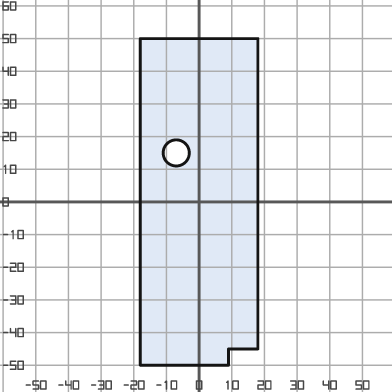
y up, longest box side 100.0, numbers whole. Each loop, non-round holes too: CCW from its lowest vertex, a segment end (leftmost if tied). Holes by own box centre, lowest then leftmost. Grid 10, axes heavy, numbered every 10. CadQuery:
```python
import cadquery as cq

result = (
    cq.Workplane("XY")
    .moveTo(-18.0, -50.0)
    .lineTo(9.0, -50.0)
    .lineTo(9.0, -45.0)
    .lineTo(18.0, -45.0)
    .lineTo(18.0, 50.0)
    .lineTo(-18.0, 50.0)
    .close()
    .moveTo(-7.0, 15.0)
    .circle(4.0)
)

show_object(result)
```